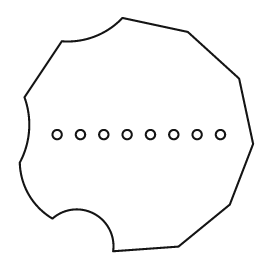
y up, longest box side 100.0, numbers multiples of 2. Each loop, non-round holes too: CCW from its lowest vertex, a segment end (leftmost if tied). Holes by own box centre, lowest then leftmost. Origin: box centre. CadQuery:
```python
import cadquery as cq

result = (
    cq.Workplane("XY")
    .moveTo(-10.0, -50.0)
    .lineTo(18.0, -48.0)
    .lineTo(40.0, -30.0)
    .lineTo(50.0, -4.0)
    .lineTo(44.0, 24.0)
    .lineTo(22.0, 44.0)
    .lineTo(-6.0, 50.0)
    .threePointArc((-18.0, 42.0), (-32.0, 40.0))
    .lineTo(-48.0, 16.0)
    .threePointArc((-46.0, 2.0), (-50.0, -12.0))
    .threePointArc((-46.0, -26.0), (-36.0, -36.0))
    .threePointArc((-18.0, -34.0), (-10.0, -50.0))
    .close()
    .moveTo(-34.0, 0.0)
    .circle(2.0)
    .moveTo(-24.0, 0.0)
    .circle(2.0)
    .moveTo(-14.0, 0.0)
    .circle(2.0)
    .moveTo(-4.0, 0.0)
    .circle(2.0)
    .moveTo(6.0, 0.0)
    .circle(2.0)
    .moveTo(16.0, 0.0)
    .circle(2.0)
    .moveTo(26.0, 0.0)
    .circle(2.0)
    .moveTo(36.0, 0.0)
    .circle(2.0)
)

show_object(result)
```